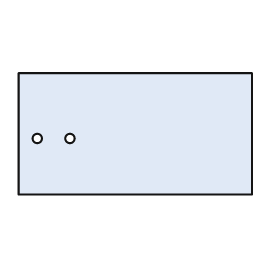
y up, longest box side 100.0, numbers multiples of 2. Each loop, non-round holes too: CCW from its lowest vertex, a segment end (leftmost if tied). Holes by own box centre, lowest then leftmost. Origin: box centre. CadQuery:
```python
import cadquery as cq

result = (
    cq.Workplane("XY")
    .moveTo(-50.0, -26.0)
    .lineTo(50.0, -26.0)
    .lineTo(50.0, 26.0)
    .lineTo(-50.0, 26.0)
    .close()
    .moveTo(-42.0, -2.0)
    .circle(2.0)
    .moveTo(-28.0, -2.0)
    .circle(2.0)
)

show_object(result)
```